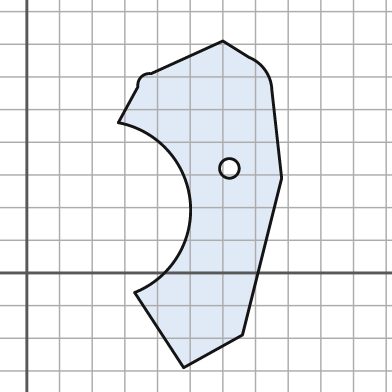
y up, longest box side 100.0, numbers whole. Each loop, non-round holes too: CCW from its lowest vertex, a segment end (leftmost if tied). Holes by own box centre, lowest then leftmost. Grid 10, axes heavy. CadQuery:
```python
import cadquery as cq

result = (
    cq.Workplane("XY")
    .moveTo(48.0, -29.0)
    .lineTo(66.0, -19.0)
    .lineTo(78.0, 29.0)
    .lineTo(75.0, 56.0)
    .threePointArc((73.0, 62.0), (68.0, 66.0))
    .lineTo(60.0, 71.0)
    .lineTo(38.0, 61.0)
    .threePointArc((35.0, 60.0), (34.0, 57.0))
    .lineTo(28.0, 46.0)
    .threePointArc((50.0, 22.0), (33.0, -6.0))
    .close()
    .moveTo(62.0, 32.0)
    .circle(3.0)
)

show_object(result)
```